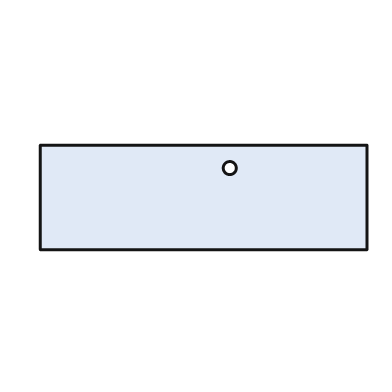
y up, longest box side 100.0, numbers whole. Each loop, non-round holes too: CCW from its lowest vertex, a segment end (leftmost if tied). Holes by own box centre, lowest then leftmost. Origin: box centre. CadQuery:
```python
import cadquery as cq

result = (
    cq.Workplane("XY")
    .moveTo(-50.0, -16.0)
    .lineTo(50.0, -16.0)
    .lineTo(50.0, 16.0)
    .lineTo(-50.0, 16.0)
    .close()
    .moveTo(8.0, 9.0)
    .circle(2.0)
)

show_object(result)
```